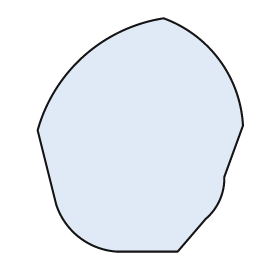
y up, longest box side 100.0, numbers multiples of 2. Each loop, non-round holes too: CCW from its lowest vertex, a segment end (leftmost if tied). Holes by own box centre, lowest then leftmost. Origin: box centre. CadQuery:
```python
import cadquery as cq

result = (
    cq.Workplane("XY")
    .moveTo(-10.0, -50.0)
    .lineTo(16.0, -50.0)
    .lineTo(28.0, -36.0)
    .threePointArc((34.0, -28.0), (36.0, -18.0))
    .lineTo(44.0, 4.0)
    .threePointArc((34.0, 32.0), (10.0, 50.0))
    .threePointArc((-24.0, 34.0), (-44.0, 2.0))
    .lineTo(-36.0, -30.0)
    .threePointArc((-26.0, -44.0), (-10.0, -50.0))
    .close()
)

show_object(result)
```